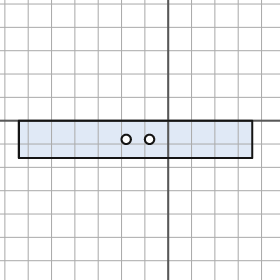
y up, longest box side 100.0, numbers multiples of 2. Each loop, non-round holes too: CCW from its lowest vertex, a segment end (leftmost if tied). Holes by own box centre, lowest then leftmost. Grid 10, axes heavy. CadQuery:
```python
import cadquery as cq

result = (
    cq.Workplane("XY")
    .moveTo(-64.0, -16.0)
    .lineTo(36.0, -16.0)
    .lineTo(36.0, 0.0)
    .lineTo(-64.0, 0.0)
    .close()
    .moveTo(-18.0, -8.0)
    .circle(2.0)
    .moveTo(-8.0, -8.0)
    .circle(2.0)
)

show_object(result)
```